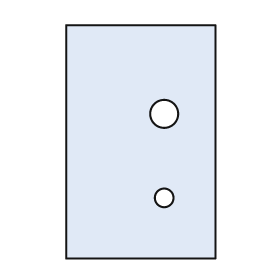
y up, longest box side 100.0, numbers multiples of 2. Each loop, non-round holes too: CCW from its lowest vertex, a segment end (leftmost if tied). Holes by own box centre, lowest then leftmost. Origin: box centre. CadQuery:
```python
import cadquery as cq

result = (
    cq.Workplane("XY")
    .moveTo(-32.0, -50.0)
    .lineTo(32.0, -50.0)
    .lineTo(32.0, 50.0)
    .lineTo(-32.0, 50.0)
    .close()
    .moveTo(10.0, -24.0)
    .circle(4.0)
    .moveTo(10.0, 12.0)
    .circle(6.0)
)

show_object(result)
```